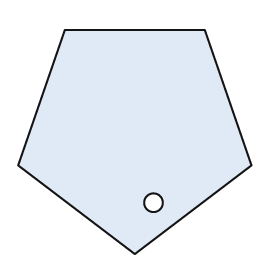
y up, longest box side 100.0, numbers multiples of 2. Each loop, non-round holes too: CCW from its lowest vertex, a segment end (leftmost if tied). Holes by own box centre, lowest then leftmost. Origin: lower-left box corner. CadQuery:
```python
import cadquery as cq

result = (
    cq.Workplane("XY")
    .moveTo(50.0, 0.0)
    .lineTo(100.0, 38.0)
    .lineTo(80.0, 96.0)
    .lineTo(20.0, 96.0)
    .lineTo(0.0, 38.0)
    .close()
    .moveTo(58.0, 22.0)
    .circle(4.0)
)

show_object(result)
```